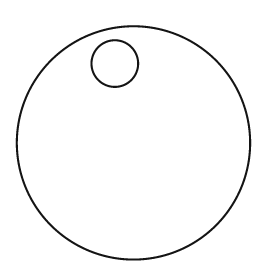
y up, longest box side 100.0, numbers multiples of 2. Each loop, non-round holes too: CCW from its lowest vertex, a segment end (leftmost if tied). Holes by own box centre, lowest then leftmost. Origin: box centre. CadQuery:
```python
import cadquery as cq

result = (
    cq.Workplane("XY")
    .moveTo(0.0, 0.0)
    .circle(50.0)
    .moveTo(-8.0, 34.0)
    .circle(10.0)
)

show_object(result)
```